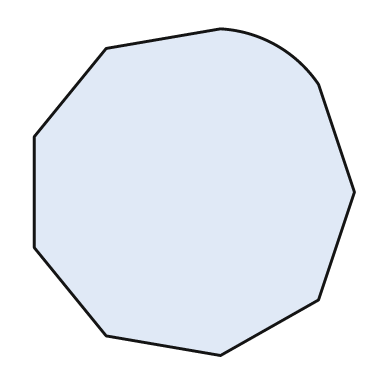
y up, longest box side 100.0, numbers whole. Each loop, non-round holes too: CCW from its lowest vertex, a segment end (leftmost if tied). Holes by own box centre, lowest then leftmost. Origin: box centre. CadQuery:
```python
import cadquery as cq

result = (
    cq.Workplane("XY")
    .moveTo(8.0, -50.0)
    .lineTo(38.0, -33.0)
    .lineTo(49.0, 0.0)
    .lineTo(38.0, 33.0)
    .threePointArc((25.0, 45.0), (8.0, 50.0))
    .lineTo(-27.0, 44.0)
    .lineTo(-49.0, 17.0)
    .lineTo(-49.0, -17.0)
    .lineTo(-27.0, -44.0)
    .close()
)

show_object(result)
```